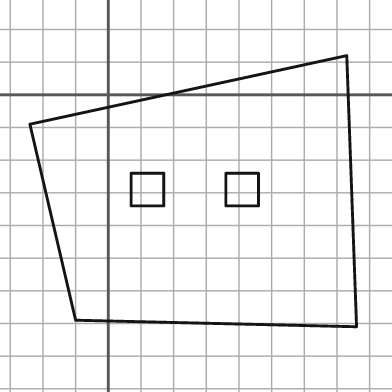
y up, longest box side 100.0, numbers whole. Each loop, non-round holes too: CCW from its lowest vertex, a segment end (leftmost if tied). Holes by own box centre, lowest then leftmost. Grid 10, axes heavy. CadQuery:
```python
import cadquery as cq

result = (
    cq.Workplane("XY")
    .moveTo(76.0, -71.0)
    .lineTo(73.0, 12.0)
    .lineTo(-24.0, -9.0)
    .lineTo(-10.0, -69.0)
    .close()
    .moveTo(7.0, -34.0)
    .lineTo(17.0, -34.0)
    .lineTo(17.0, -24.0)
    .lineTo(7.0, -24.0)
    .close()
    .moveTo(36.0, -34.0)
    .lineTo(46.0, -34.0)
    .lineTo(46.0, -24.0)
    .lineTo(36.0, -24.0)
    .close()
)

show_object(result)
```